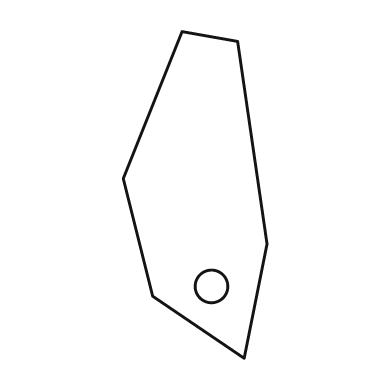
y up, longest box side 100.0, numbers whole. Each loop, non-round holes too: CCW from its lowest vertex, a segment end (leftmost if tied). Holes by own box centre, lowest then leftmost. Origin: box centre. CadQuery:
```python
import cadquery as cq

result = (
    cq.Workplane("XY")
    .moveTo(15.0, -50.0)
    .lineTo(22.0, -15.0)
    .lineTo(13.0, 47.0)
    .lineTo(-4.0, 50.0)
    .lineTo(-22.0, 5.0)
    .lineTo(-13.0, -31.0)
    .close()
    .moveTo(5.0, -28.0)
    .circle(5.0)
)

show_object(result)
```